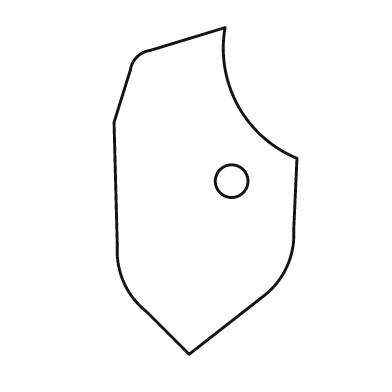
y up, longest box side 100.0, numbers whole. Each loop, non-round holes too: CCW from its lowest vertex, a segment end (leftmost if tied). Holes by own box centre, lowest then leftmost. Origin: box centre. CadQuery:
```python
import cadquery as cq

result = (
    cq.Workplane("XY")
    .moveTo(-5.0, -50.0)
    .lineTo(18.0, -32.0)
    .threePointArc((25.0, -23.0), (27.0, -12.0))
    .lineTo(28.0, 10.0)
    .threePointArc((10.0, 26.0), (6.0, 50.0))
    .lineTo(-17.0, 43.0)
    .threePointArc((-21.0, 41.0), (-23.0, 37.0))
    .lineTo(-28.0, 21.0)
    .lineTo(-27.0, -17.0)
    .threePointArc((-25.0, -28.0), (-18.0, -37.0))
    .close()
    .moveTo(8.0, 3.0)
    .circle(5.0)
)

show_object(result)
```